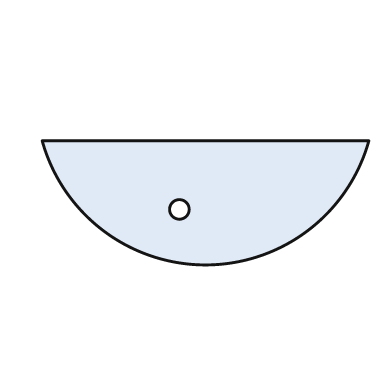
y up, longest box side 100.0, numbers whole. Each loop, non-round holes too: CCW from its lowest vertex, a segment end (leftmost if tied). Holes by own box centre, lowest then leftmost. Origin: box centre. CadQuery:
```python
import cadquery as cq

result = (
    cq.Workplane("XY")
    .moveTo(-50.0, 19.0)
    .threePointArc((0.0, -19.0), (50.0, 19.0))
    .close()
    .moveTo(-8.0, -2.0)
    .circle(3.0)
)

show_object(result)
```